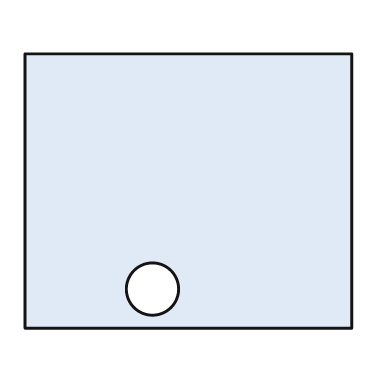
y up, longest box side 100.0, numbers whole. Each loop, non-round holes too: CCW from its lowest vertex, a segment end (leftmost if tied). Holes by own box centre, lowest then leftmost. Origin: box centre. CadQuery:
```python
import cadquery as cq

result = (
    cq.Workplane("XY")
    .moveTo(-50.0, -42.0)
    .lineTo(50.0, -42.0)
    .lineTo(50.0, 42.0)
    .lineTo(-50.0, 42.0)
    .close()
    .moveTo(-11.0, -30.0)
    .circle(8.0)
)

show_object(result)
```